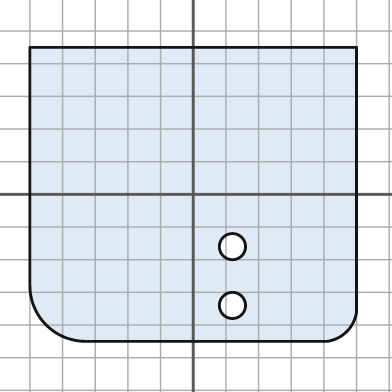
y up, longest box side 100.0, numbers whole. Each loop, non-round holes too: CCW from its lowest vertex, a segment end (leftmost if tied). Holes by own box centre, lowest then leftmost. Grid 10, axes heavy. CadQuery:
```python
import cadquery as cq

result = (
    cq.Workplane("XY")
    .moveTo(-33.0, -45.0)
    .lineTo(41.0, -45.0)
    .threePointArc((47.0, -42.0), (50.0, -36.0))
    .lineTo(50.0, 45.0)
    .lineTo(-50.0, 45.0)
    .lineTo(-50.0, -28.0)
    .threePointArc((-45.0, -40.0), (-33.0, -45.0))
    .close()
    .moveTo(12.0, -34.0)
    .circle(4.0)
    .moveTo(12.0, -16.0)
    .circle(4.0)
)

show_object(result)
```